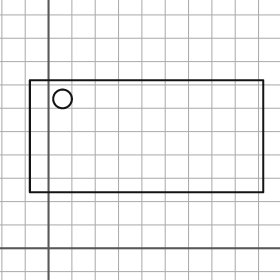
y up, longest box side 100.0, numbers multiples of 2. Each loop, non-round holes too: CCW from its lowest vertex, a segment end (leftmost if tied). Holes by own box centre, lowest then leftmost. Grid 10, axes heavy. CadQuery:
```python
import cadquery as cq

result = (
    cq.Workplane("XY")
    .moveTo(-8.0, 24.0)
    .lineTo(92.0, 24.0)
    .lineTo(92.0, 72.0)
    .lineTo(-8.0, 72.0)
    .close()
    .moveTo(6.0, 64.0)
    .circle(4.0)
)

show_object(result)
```